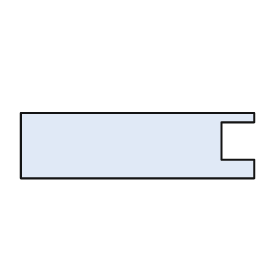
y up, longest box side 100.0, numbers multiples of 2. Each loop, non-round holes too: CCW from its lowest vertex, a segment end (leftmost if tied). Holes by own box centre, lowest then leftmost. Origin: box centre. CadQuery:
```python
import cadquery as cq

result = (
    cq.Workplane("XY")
    .moveTo(-50.0, -14.0)
    .lineTo(50.0, -14.0)
    .lineTo(50.0, -6.0)
    .lineTo(36.0, -6.0)
    .lineTo(36.0, 10.0)
    .lineTo(50.0, 10.0)
    .lineTo(50.0, 14.0)
    .lineTo(-50.0, 14.0)
    .close()
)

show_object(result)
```